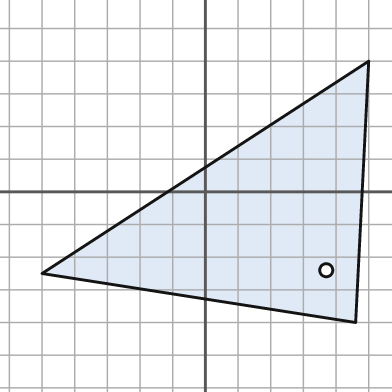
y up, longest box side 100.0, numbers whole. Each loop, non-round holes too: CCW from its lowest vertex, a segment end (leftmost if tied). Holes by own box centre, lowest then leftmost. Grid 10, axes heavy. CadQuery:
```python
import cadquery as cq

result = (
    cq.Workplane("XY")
    .moveTo(46.0, -40.0)
    .lineTo(50.0, 40.0)
    .lineTo(-50.0, -25.0)
    .close()
    .moveTo(37.0, -24.0)
    .circle(2.0)
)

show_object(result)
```